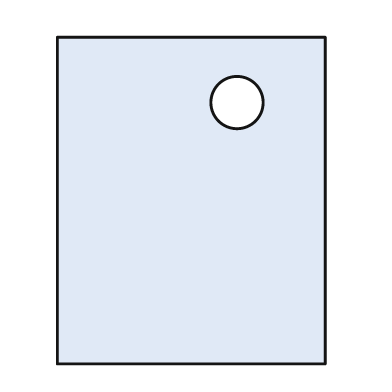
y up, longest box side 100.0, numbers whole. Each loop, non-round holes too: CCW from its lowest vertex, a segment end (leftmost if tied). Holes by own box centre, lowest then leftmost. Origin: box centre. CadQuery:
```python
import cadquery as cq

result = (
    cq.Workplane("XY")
    .moveTo(-41.0, -50.0)
    .lineTo(41.0, -50.0)
    .lineTo(41.0, 50.0)
    .lineTo(-41.0, 50.0)
    .close()
    .moveTo(14.0, 30.0)
    .circle(8.0)
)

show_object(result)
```